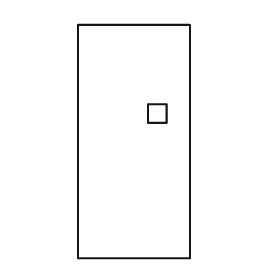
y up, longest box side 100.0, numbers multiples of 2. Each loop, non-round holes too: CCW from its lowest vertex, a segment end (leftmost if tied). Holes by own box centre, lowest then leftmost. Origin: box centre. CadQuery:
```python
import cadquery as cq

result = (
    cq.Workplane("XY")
    .moveTo(-24.0, -50.0)
    .lineTo(24.0, -50.0)
    .lineTo(24.0, 50.0)
    .lineTo(-24.0, 50.0)
    .close()
    .moveTo(6.0, 8.0)
    .lineTo(14.0, 8.0)
    .lineTo(14.0, 16.0)
    .lineTo(6.0, 16.0)
    .close()
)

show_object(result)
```